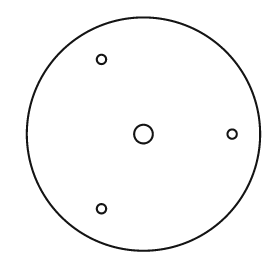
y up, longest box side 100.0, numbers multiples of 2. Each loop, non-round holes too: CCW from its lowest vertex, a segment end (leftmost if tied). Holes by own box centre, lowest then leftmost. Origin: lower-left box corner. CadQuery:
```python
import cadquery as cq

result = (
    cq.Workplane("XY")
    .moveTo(50.0, 50.0)
    .circle(50.0)
    .moveTo(32.0, 18.0)
    .circle(2.0)
    .moveTo(50.0, 50.0)
    .circle(4.0)
    .moveTo(88.0, 50.0)
    .circle(2.0)
    .moveTo(32.0, 82.0)
    .circle(2.0)
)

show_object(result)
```